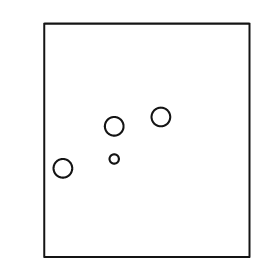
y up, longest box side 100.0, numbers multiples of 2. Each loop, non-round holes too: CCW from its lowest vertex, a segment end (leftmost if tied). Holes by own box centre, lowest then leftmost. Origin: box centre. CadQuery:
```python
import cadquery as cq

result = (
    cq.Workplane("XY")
    .moveTo(-44.0, -50.0)
    .lineTo(44.0, -50.0)
    .lineTo(44.0, 50.0)
    .lineTo(-44.0, 50.0)
    .close()
    .moveTo(-36.0, -12.0)
    .circle(4.0)
    .moveTo(-14.0, -8.0)
    .circle(2.0)
    .moveTo(-14.0, 6.0)
    .circle(4.0)
    .moveTo(6.0, 10.0)
    .circle(4.0)
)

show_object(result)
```